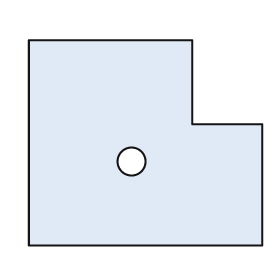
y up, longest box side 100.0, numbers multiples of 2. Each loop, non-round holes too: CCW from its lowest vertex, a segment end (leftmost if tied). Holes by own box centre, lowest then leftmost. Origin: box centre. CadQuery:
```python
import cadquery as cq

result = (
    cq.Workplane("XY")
    .moveTo(-50.0, -44.0)
    .lineTo(50.0, -44.0)
    .lineTo(50.0, 8.0)
    .lineTo(20.0, 8.0)
    .lineTo(20.0, 44.0)
    .lineTo(-50.0, 44.0)
    .close()
    .moveTo(-6.0, -8.0)
    .circle(6.0)
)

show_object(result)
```